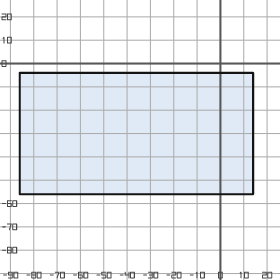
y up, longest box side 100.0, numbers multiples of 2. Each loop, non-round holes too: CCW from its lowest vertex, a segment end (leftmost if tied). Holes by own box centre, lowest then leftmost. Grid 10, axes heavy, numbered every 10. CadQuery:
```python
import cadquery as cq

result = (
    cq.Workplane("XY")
    .moveTo(-86.0, -56.0)
    .lineTo(14.0, -56.0)
    .lineTo(14.0, -4.0)
    .lineTo(-86.0, -4.0)
    .close()
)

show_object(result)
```